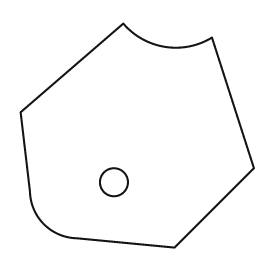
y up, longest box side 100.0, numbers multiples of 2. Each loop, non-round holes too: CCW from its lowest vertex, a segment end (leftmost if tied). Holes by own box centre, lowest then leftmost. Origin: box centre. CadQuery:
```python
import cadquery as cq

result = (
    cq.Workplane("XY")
    .moveTo(16.0, -48.0)
    .lineTo(50.0, -14.0)
    .lineTo(32.0, 42.0)
    .threePointArc((12.0, 38.0), (-6.0, 48.0))
    .lineTo(-50.0, 10.0)
    .lineTo(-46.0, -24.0)
    .threePointArc((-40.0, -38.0), (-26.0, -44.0))
    .close()
    .moveTo(-10.0, -20.0)
    .circle(6.0)
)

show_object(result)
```